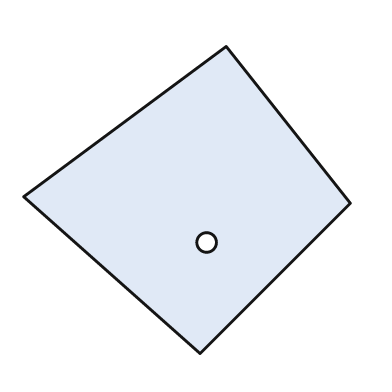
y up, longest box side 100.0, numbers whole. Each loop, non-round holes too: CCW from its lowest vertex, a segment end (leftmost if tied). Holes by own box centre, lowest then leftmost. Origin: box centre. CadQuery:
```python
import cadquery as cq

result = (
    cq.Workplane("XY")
    .moveTo(4.0, -47.0)
    .lineTo(50.0, -1.0)
    .lineTo(12.0, 47.0)
    .lineTo(-50.0, 1.0)
    .close()
    .moveTo(6.0, -13.0)
    .circle(3.0)
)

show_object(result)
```